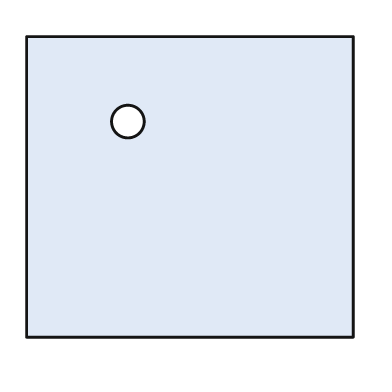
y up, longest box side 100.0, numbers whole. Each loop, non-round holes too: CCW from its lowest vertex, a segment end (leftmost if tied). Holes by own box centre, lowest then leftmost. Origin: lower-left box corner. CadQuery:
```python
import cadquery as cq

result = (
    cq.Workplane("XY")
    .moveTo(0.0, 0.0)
    .lineTo(100.0, 0.0)
    .lineTo(100.0, 92.0)
    .lineTo(0.0, 92.0)
    .close()
    .moveTo(31.0, 66.0)
    .circle(5.0)
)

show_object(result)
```